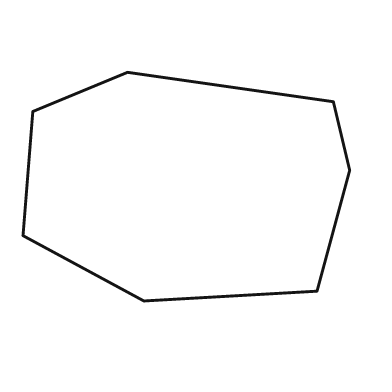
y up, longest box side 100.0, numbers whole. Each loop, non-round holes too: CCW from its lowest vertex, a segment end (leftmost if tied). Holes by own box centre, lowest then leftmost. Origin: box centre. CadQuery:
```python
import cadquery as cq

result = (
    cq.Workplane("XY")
    .moveTo(-13.0, -35.0)
    .lineTo(40.0, -32.0)
    .lineTo(50.0, 5.0)
    .lineTo(45.0, 26.0)
    .lineTo(-18.0, 35.0)
    .lineTo(-47.0, 23.0)
    .lineTo(-50.0, -15.0)
    .close()
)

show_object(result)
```